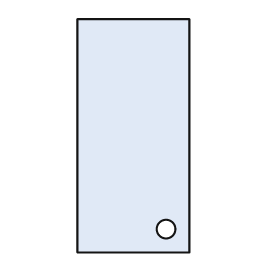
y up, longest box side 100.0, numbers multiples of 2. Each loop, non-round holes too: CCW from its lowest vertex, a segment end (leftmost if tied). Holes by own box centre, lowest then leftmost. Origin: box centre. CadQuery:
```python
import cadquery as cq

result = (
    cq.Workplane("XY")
    .moveTo(-24.0, -50.0)
    .lineTo(24.0, -50.0)
    .lineTo(24.0, 50.0)
    .lineTo(-24.0, 50.0)
    .close()
    .moveTo(14.0, -40.0)
    .circle(4.0)
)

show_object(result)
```